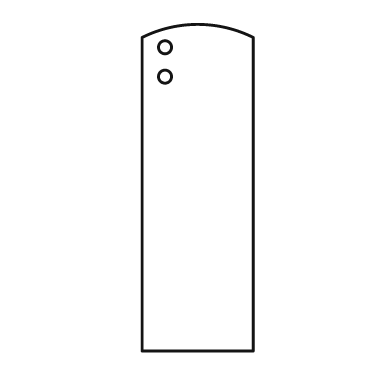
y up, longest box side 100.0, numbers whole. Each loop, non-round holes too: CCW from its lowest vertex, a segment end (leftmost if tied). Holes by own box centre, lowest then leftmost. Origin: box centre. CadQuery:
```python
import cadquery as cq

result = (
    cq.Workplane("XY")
    .moveTo(-17.0, -50.0)
    .lineTo(17.0, -50.0)
    .lineTo(17.0, 46.0)
    .threePointArc((0.0, 50.0), (-17.0, 46.0))
    .close()
    .moveTo(-10.0, 34.0)
    .circle(2.0)
    .moveTo(-10.0, 43.0)
    .circle(2.0)
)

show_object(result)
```